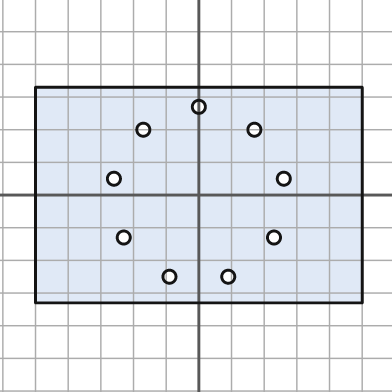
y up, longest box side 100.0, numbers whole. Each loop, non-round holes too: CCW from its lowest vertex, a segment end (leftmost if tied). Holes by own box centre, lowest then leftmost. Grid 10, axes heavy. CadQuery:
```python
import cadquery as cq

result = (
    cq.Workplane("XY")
    .moveTo(-50.0, -33.0)
    .lineTo(50.0, -33.0)
    .lineTo(50.0, 33.0)
    .lineTo(-50.0, 33.0)
    .close()
    .moveTo(-9.0, -25.0)
    .circle(2.0)
    .moveTo(9.0, -25.0)
    .circle(2.0)
    .moveTo(-23.0, -13.0)
    .circle(2.0)
    .moveTo(23.0, -13.0)
    .circle(2.0)
    .moveTo(-26.0, 5.0)
    .circle(2.0)
    .moveTo(26.0, 5.0)
    .circle(2.0)
    .moveTo(-17.0, 20.0)
    .circle(2.0)
    .moveTo(17.0, 20.0)
    .circle(2.0)
    .moveTo(0.0, 27.0)
    .circle(2.0)
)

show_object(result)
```